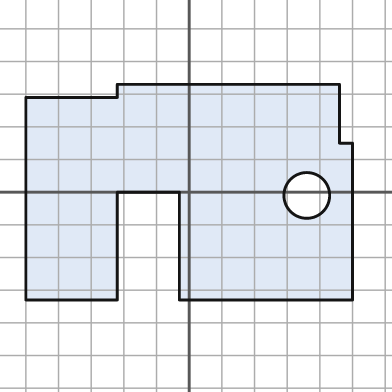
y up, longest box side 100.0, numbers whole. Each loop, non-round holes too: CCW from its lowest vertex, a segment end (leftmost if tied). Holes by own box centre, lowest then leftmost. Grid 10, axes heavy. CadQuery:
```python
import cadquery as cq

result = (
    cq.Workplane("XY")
    .moveTo(-50.0, -33.0)
    .lineTo(-22.0, -33.0)
    .lineTo(-22.0, 0.0)
    .lineTo(-3.0, 0.0)
    .lineTo(-3.0, -33.0)
    .lineTo(50.0, -33.0)
    .lineTo(50.0, 15.0)
    .lineTo(46.0, 15.0)
    .lineTo(46.0, 33.0)
    .lineTo(-22.0, 33.0)
    .lineTo(-22.0, 29.0)
    .lineTo(-50.0, 29.0)
    .close()
    .moveTo(36.0, -1.0)
    .circle(7.0)
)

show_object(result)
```